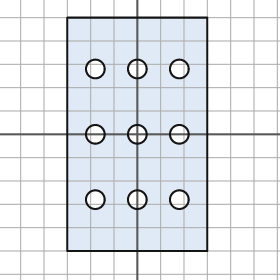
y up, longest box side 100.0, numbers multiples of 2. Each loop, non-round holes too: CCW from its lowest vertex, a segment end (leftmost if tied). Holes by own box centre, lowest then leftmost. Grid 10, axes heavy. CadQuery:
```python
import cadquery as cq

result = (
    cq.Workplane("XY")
    .moveTo(-30.0, -50.0)
    .lineTo(30.0, -50.0)
    .lineTo(30.0, 50.0)
    .lineTo(-30.0, 50.0)
    .close()
    .moveTo(-18.0, -28.0)
    .circle(4.0)
    .moveTo(0.0, -28.0)
    .circle(4.0)
    .moveTo(18.0, -28.0)
    .circle(4.0)
    .moveTo(-18.0, 0.0)
    .circle(4.0)
    .moveTo(0.0, 0.0)
    .circle(4.0)
    .moveTo(18.0, 0.0)
    .circle(4.0)
    .moveTo(-18.0, 28.0)
    .circle(4.0)
    .moveTo(0.0, 28.0)
    .circle(4.0)
    .moveTo(18.0, 28.0)
    .circle(4.0)
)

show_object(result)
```